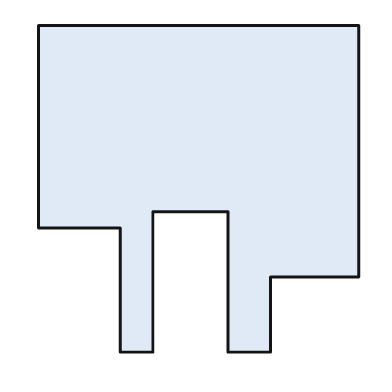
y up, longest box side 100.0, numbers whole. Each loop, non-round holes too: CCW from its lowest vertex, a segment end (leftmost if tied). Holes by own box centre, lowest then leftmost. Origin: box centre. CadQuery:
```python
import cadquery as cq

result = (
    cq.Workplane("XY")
    .moveTo(-24.0, -50.0)
    .lineTo(-14.0, -50.0)
    .lineTo(-14.0, -7.0)
    .lineTo(9.0, -7.0)
    .lineTo(9.0, -50.0)
    .lineTo(22.0, -50.0)
    .lineTo(22.0, -27.0)
    .lineTo(49.0, -27.0)
    .lineTo(49.0, 50.0)
    .lineTo(-49.0, 50.0)
    .lineTo(-49.0, -12.0)
    .lineTo(-24.0, -12.0)
    .close()
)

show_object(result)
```